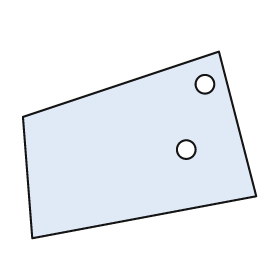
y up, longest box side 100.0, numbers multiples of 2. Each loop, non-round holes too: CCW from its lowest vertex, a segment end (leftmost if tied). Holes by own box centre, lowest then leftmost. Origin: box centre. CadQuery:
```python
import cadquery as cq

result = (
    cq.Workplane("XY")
    .moveTo(-46.0, -40.0)
    .lineTo(50.0, -22.0)
    .lineTo(34.0, 40.0)
    .lineTo(-50.0, 12.0)
    .close()
    .moveTo(20.0, -2.0)
    .circle(4.0)
    .moveTo(28.0, 26.0)
    .circle(4.0)
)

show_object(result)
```